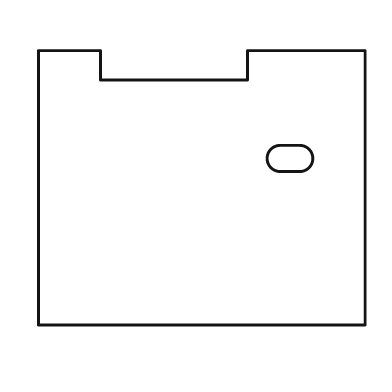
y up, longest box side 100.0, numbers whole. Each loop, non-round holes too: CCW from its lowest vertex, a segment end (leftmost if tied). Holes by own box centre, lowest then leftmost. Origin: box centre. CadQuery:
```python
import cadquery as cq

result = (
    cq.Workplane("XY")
    .moveTo(-50.0, -42.0)
    .lineTo(50.0, -42.0)
    .lineTo(50.0, 42.0)
    .lineTo(14.0, 42.0)
    .lineTo(14.0, 33.0)
    .lineTo(-31.0, 33.0)
    .lineTo(-31.0, 42.0)
    .lineTo(-50.0, 42.0)
    .close()
    .moveTo(24.0, 5.0)
    .lineTo(30.0, 5.0)
    .threePointArc((34.0, 9.0), (30.0, 13.0))
    .lineTo(24.0, 13.0)
    .threePointArc((20.0, 9.0), (24.0, 5.0))
    .close()
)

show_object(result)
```